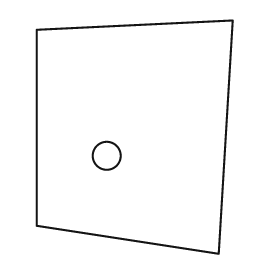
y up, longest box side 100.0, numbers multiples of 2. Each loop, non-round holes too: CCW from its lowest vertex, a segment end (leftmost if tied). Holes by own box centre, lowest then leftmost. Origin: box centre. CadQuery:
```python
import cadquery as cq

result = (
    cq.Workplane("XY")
    .moveTo(36.0, -50.0)
    .lineTo(42.0, 50.0)
    .lineTo(-42.0, 46.0)
    .lineTo(-42.0, -38.0)
    .close()
    .moveTo(-12.0, -8.0)
    .circle(6.0)
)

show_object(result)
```